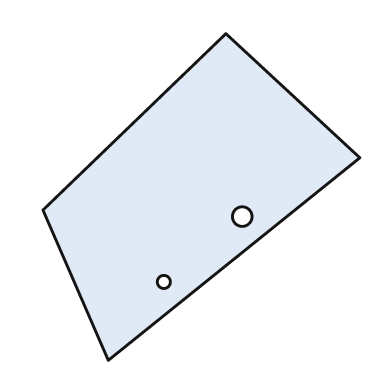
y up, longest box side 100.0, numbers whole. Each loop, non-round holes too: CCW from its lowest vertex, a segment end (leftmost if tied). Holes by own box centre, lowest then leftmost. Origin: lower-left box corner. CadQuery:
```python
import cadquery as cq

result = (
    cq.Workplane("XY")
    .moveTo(20.0, 0.0)
    .lineTo(97.0, 62.0)
    .lineTo(56.0, 100.0)
    .lineTo(0.0, 46.0)
    .close()
    .moveTo(37.0, 24.0)
    .circle(2.0)
    .moveTo(61.0, 44.0)
    .circle(3.0)
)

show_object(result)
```